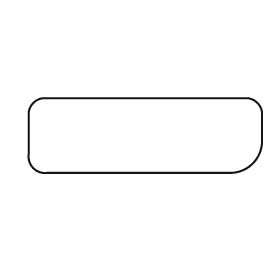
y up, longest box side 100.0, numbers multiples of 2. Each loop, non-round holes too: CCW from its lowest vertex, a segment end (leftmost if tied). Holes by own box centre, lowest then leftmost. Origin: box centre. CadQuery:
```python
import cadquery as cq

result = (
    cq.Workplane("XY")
    .moveTo(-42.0, -16.0)
    .lineTo(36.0, -16.0)
    .threePointArc((46.0, -12.0), (50.0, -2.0))
    .lineTo(50.0, 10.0)
    .threePointArc((48.0, 14.0), (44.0, 16.0))
    .lineTo(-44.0, 16.0)
    .threePointArc((-48.0, 14.0), (-50.0, 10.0))
    .lineTo(-50.0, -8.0)
    .threePointArc((-48.0, -14.0), (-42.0, -16.0))
    .close()
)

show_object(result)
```